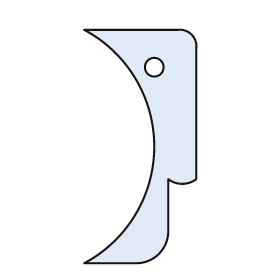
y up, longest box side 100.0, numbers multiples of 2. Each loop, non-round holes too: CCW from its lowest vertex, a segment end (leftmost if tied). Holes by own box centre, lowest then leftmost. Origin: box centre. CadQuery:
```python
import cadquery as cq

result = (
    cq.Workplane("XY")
    .moveTo(-24.0, -50.0)
    .lineTo(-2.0, -50.0)
    .threePointArc((8.0, -46.0), (12.0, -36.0))
    .lineTo(12.0, -14.0)
    .threePointArc((18.0, -16.0), (24.0, -14.0))
    .lineTo(24.0, 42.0)
    .threePointArc((22.0, 48.0), (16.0, 50.0))
    .lineTo(-24.0, 50.0)
    .threePointArc((6.0, 0.0), (-24.0, -50.0))
    .close()
    .moveTo(6.0, 34.0)
    .circle(4.0)
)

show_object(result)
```